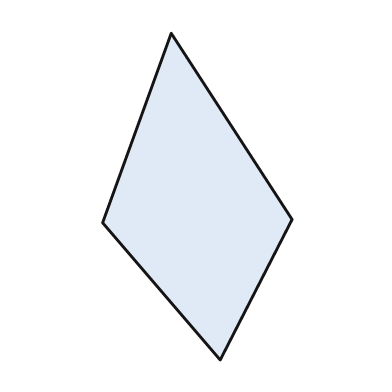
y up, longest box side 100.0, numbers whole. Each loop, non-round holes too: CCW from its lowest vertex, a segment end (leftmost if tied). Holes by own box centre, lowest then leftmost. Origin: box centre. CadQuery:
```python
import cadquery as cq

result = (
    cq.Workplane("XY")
    .moveTo(7.0, -50.0)
    .lineTo(29.0, -7.0)
    .lineTo(-8.0, 50.0)
    .lineTo(-29.0, -8.0)
    .close()
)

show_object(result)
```